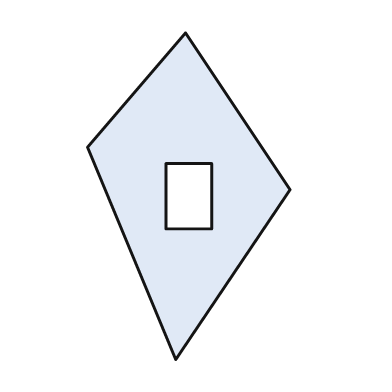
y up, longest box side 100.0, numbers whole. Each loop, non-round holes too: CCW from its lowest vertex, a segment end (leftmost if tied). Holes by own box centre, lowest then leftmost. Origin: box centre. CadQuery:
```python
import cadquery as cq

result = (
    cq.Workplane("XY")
    .moveTo(-4.0, -50.0)
    .lineTo(31.0, 2.0)
    .lineTo(-1.0, 50.0)
    .lineTo(-31.0, 15.0)
    .close()
    .moveTo(-7.0, -10.0)
    .lineTo(7.0, -10.0)
    .lineTo(7.0, 10.0)
    .lineTo(-7.0, 10.0)
    .close()
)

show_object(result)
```